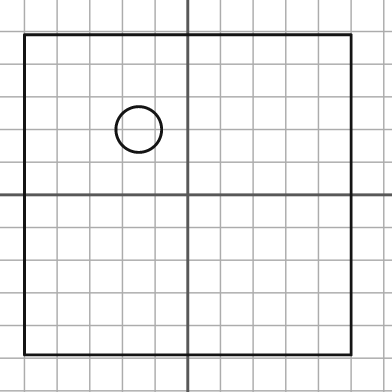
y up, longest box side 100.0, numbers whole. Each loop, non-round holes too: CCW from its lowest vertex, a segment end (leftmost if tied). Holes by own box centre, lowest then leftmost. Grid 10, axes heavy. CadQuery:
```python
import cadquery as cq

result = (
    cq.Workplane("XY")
    .moveTo(-50.0, -49.0)
    .lineTo(50.0, -49.0)
    .lineTo(50.0, 49.0)
    .lineTo(-50.0, 49.0)
    .close()
    .moveTo(-15.0, 20.0)
    .circle(7.0)
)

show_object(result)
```